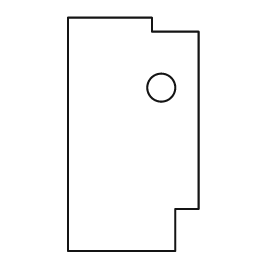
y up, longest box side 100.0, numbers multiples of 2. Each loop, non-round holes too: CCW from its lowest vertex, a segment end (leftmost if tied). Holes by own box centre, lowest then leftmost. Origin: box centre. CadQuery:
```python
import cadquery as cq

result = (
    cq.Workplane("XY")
    .moveTo(-28.0, -50.0)
    .lineTo(18.0, -50.0)
    .lineTo(18.0, -32.0)
    .lineTo(28.0, -32.0)
    .lineTo(28.0, 44.0)
    .lineTo(8.0, 44.0)
    .lineTo(8.0, 50.0)
    .lineTo(-28.0, 50.0)
    .close()
    .moveTo(12.0, 20.0)
    .circle(6.0)
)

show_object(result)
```